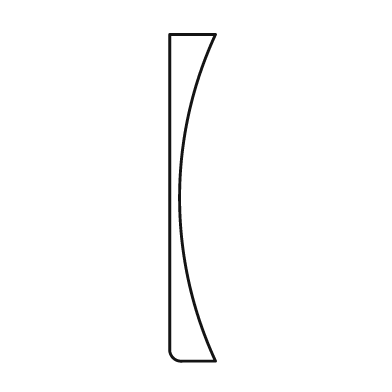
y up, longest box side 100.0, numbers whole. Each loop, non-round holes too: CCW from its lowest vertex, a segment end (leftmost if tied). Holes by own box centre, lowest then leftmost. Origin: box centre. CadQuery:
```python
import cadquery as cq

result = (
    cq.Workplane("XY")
    .moveTo(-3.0, -50.0)
    .lineTo(7.0, -50.0)
    .threePointArc((-4.0, 0.0), (7.0, 50.0))
    .lineTo(-7.0, 50.0)
    .lineTo(-7.0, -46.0)
    .threePointArc((-6.0, -49.0), (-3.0, -50.0))
    .close()
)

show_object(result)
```